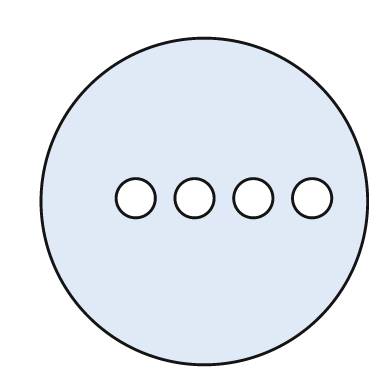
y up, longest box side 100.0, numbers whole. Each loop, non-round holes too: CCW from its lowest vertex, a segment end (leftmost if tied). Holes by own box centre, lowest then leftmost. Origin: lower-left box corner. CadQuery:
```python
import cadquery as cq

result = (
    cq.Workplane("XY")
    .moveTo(50.0, 50.0)
    .circle(50.0)
    .moveTo(29.0, 51.0)
    .circle(6.0)
    .moveTo(47.0, 51.0)
    .circle(6.0)
    .moveTo(65.0, 51.0)
    .circle(6.0)
    .moveTo(83.0, 51.0)
    .circle(6.0)
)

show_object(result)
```